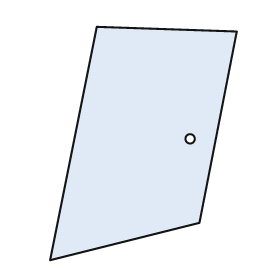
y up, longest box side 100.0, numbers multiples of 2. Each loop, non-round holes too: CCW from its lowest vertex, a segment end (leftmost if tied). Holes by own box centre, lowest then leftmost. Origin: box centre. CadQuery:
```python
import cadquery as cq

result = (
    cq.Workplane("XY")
    .moveTo(-40.0, -50.0)
    .lineTo(24.0, -34.0)
    .lineTo(40.0, 48.0)
    .lineTo(-20.0, 50.0)
    .close()
    .moveTo(20.0, 2.0)
    .circle(2.0)
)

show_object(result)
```